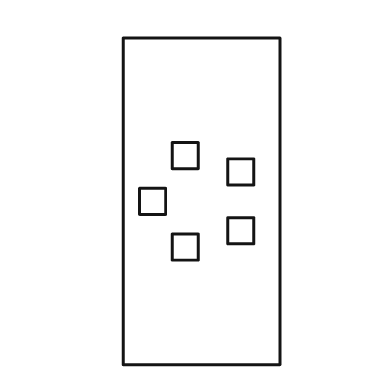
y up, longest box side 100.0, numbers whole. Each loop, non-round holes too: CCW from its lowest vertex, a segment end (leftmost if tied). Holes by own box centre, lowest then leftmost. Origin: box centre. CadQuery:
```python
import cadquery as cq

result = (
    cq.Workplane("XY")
    .moveTo(-24.0, -50.0)
    .lineTo(24.0, -50.0)
    .lineTo(24.0, 50.0)
    .lineTo(-24.0, 50.0)
    .close()
    .moveTo(-9.0, -18.0)
    .lineTo(-1.0, -18.0)
    .lineTo(-1.0, -10.0)
    .lineTo(-9.0, -10.0)
    .close()
    .moveTo(8.0, -13.0)
    .lineTo(16.0, -13.0)
    .lineTo(16.0, -5.0)
    .lineTo(8.0, -5.0)
    .close()
    .moveTo(-19.0, -4.0)
    .lineTo(-11.0, -4.0)
    .lineTo(-11.0, 4.0)
    .lineTo(-19.0, 4.0)
    .close()
    .moveTo(8.0, 5.0)
    .lineTo(16.0, 5.0)
    .lineTo(16.0, 13.0)
    .lineTo(8.0, 13.0)
    .close()
    .moveTo(-9.0, 10.0)
    .lineTo(-1.0, 10.0)
    .lineTo(-1.0, 18.0)
    .lineTo(-9.0, 18.0)
    .close()
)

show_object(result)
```